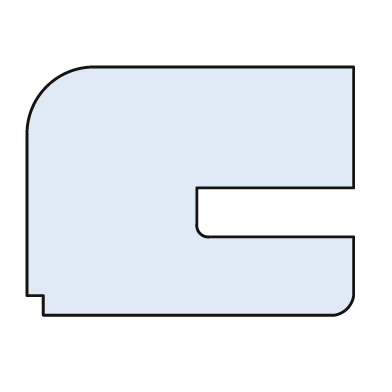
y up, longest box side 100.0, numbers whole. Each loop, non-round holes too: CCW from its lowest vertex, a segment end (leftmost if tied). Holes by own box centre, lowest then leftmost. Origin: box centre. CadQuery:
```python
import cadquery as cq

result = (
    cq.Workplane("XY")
    .moveTo(-45.0, -38.0)
    .lineTo(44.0, -38.0)
    .threePointArc((48.0, -36.0), (50.0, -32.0))
    .lineTo(50.0, -14.0)
    .lineTo(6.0, -14.0)
    .threePointArc((3.0, -13.0), (2.0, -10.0))
    .lineTo(2.0, 1.0)
    .lineTo(50.0, 1.0)
    .lineTo(50.0, 38.0)
    .lineTo(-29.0, 38.0)
    .threePointArc((-44.0, 32.0), (-50.0, 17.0))
    .lineTo(-50.0, -32.0)
    .lineTo(-45.0, -32.0)
    .close()
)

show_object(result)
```